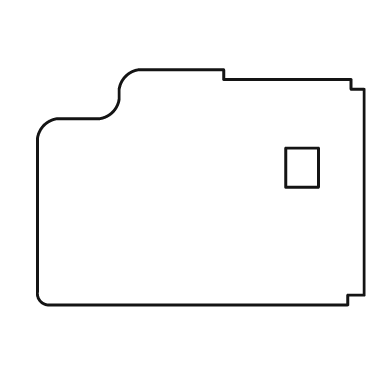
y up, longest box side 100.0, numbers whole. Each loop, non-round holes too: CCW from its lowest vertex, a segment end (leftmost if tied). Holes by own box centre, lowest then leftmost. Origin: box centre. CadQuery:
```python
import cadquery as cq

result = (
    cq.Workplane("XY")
    .moveTo(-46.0, -36.0)
    .lineTo(45.0, -36.0)
    .lineTo(45.0, -33.0)
    .lineTo(50.0, -33.0)
    .lineTo(50.0, 30.0)
    .lineTo(46.0, 30.0)
    .lineTo(46.0, 33.0)
    .lineTo(7.0, 33.0)
    .lineTo(7.0, 36.0)
    .lineTo(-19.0, 36.0)
    .threePointArc((-23.0, 34.0), (-25.0, 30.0))
    .lineTo(-25.0, 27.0)
    .threePointArc((-27.0, 23.0), (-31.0, 21.0))
    .lineTo(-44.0, 21.0)
    .threePointArc((-48.0, 19.0), (-50.0, 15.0))
    .lineTo(-50.0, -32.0)
    .threePointArc((-49.0, -35.0), (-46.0, -36.0))
    .close()
    .moveTo(26.0, 0.0)
    .lineTo(36.0, 0.0)
    .lineTo(36.0, 12.0)
    .lineTo(26.0, 12.0)
    .close()
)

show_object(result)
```